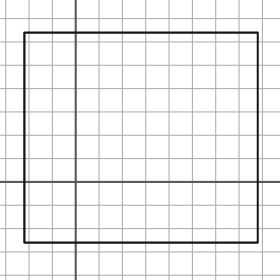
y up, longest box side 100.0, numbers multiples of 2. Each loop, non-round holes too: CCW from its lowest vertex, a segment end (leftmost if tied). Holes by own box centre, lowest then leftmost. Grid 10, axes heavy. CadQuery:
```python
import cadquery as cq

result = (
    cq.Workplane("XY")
    .moveTo(-22.0, -26.0)
    .lineTo(78.0, -26.0)
    .lineTo(78.0, 64.0)
    .lineTo(-22.0, 64.0)
    .close()
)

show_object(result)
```